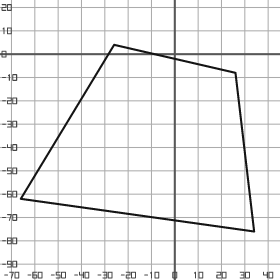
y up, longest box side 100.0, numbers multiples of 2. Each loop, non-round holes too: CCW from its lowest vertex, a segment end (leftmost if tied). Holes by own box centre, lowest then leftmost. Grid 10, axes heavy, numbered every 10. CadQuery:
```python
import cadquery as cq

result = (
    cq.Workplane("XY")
    .moveTo(34.0, -76.0)
    .lineTo(26.0, -8.0)
    .lineTo(-26.0, 4.0)
    .lineTo(-66.0, -62.0)
    .close()
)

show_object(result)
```